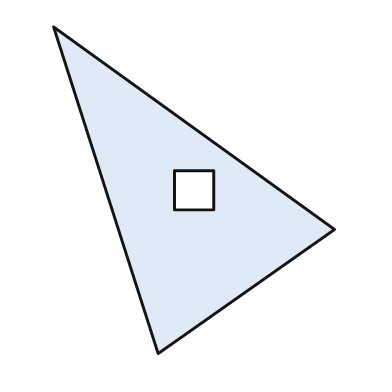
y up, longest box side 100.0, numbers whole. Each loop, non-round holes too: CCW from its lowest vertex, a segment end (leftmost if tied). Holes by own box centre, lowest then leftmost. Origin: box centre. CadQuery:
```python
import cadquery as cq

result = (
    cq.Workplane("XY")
    .moveTo(-11.0, -50.0)
    .lineTo(43.0, -12.0)
    .lineTo(-43.0, 50.0)
    .close()
    .moveTo(-6.0, -6.0)
    .lineTo(6.0, -6.0)
    .lineTo(6.0, 6.0)
    .lineTo(-6.0, 6.0)
    .close()
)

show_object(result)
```